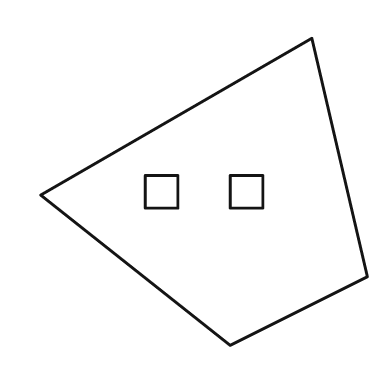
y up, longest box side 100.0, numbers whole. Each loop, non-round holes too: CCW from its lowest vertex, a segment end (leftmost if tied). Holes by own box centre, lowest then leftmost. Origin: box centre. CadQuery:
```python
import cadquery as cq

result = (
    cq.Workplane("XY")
    .moveTo(8.0, -47.0)
    .lineTo(50.0, -26.0)
    .lineTo(33.0, 47.0)
    .lineTo(-50.0, -1.0)
    .close()
    .moveTo(-18.0, -5.0)
    .lineTo(-8.0, -5.0)
    .lineTo(-8.0, 5.0)
    .lineTo(-18.0, 5.0)
    .close()
    .moveTo(8.0, -5.0)
    .lineTo(18.0, -5.0)
    .lineTo(18.0, 5.0)
    .lineTo(8.0, 5.0)
    .close()
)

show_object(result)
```